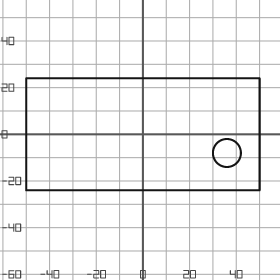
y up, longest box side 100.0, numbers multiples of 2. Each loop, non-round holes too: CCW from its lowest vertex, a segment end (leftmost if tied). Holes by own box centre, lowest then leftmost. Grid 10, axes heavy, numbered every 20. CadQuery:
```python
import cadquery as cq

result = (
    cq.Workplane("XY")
    .moveTo(-50.0, -24.0)
    .lineTo(50.0, -24.0)
    .lineTo(50.0, 24.0)
    .lineTo(-50.0, 24.0)
    .close()
    .moveTo(36.0, -8.0)
    .circle(6.0)
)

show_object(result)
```